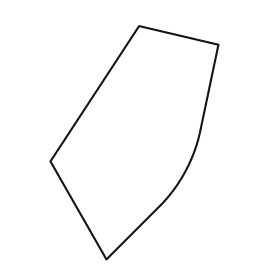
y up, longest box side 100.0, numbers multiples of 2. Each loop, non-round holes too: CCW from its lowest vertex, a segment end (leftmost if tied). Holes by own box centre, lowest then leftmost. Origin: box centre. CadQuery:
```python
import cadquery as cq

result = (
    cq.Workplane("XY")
    .moveTo(-12.0, -50.0)
    .lineTo(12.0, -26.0)
    .threePointArc((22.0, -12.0), (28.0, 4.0))
    .lineTo(36.0, 42.0)
    .lineTo(2.0, 50.0)
    .lineTo(-36.0, -8.0)
    .close()
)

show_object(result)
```